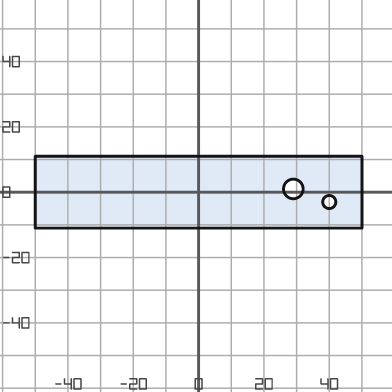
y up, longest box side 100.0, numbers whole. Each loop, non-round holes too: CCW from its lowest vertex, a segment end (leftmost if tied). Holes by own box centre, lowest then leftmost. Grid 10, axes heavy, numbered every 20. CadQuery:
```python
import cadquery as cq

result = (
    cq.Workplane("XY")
    .moveTo(-50.0, -11.0)
    .lineTo(50.0, -11.0)
    .lineTo(50.0, 11.0)
    .lineTo(-50.0, 11.0)
    .close()
    .moveTo(40.0, -3.0)
    .circle(2.0)
    .moveTo(29.0, 1.0)
    .circle(3.0)
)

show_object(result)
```